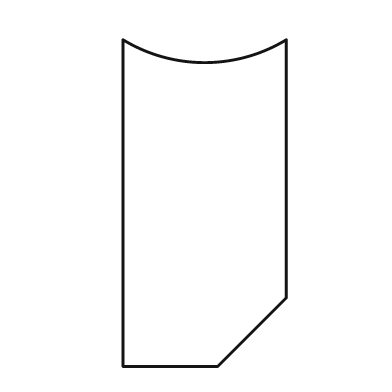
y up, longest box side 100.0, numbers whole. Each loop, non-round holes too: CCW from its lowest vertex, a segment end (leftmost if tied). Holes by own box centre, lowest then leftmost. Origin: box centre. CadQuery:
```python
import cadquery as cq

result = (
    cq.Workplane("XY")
    .moveTo(-25.0, -50.0)
    .lineTo(4.0, -50.0)
    .lineTo(25.0, -29.0)
    .lineTo(25.0, 50.0)
    .threePointArc((0.0, 43.0), (-25.0, 50.0))
    .close()
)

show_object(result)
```